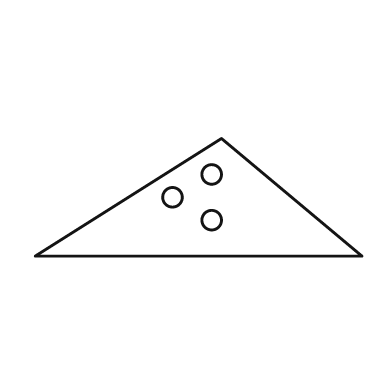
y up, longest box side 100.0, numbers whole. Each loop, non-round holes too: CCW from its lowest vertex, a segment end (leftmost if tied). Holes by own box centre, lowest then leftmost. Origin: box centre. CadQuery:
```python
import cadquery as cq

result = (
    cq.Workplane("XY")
    .moveTo(-50.0, -18.0)
    .lineTo(50.0, -18.0)
    .lineTo(7.0, 18.0)
    .close()
    .moveTo(4.0, -7.0)
    .circle(3.0)
    .moveTo(-8.0, 0.0)
    .circle(3.0)
    .moveTo(4.0, 7.0)
    .circle(3.0)
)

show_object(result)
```